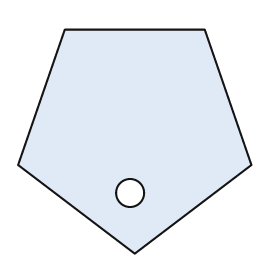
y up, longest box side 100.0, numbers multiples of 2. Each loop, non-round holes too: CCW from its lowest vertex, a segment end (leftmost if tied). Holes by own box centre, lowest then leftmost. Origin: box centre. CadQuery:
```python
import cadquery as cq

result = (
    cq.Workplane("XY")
    .moveTo(0.0, -48.0)
    .lineTo(50.0, -10.0)
    .lineTo(30.0, 48.0)
    .lineTo(-30.0, 48.0)
    .lineTo(-50.0, -10.0)
    .close()
    .moveTo(-2.0, -22.0)
    .circle(6.0)
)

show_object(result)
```